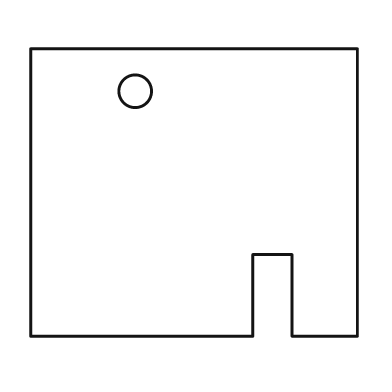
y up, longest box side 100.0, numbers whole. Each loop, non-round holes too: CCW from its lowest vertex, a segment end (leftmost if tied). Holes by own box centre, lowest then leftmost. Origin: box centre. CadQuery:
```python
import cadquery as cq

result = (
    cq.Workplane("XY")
    .moveTo(-50.0, -44.0)
    .lineTo(18.0, -44.0)
    .lineTo(18.0, -19.0)
    .lineTo(30.0, -19.0)
    .lineTo(30.0, -44.0)
    .lineTo(50.0, -44.0)
    .lineTo(50.0, 44.0)
    .lineTo(-50.0, 44.0)
    .close()
    .moveTo(-18.0, 31.0)
    .circle(5.0)
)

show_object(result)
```